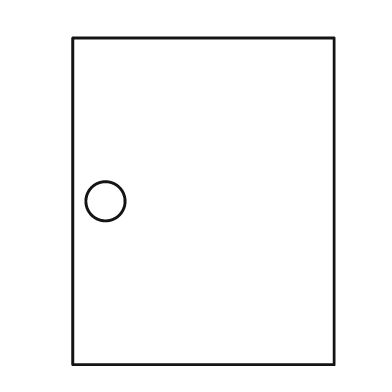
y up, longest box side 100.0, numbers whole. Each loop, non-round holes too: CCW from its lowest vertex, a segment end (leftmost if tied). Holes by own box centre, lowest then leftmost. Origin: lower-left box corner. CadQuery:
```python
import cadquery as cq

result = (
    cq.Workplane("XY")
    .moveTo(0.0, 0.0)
    .lineTo(80.0, 0.0)
    .lineTo(80.0, 100.0)
    .lineTo(0.0, 100.0)
    .close()
    .moveTo(10.0, 50.0)
    .circle(6.0)
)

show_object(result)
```